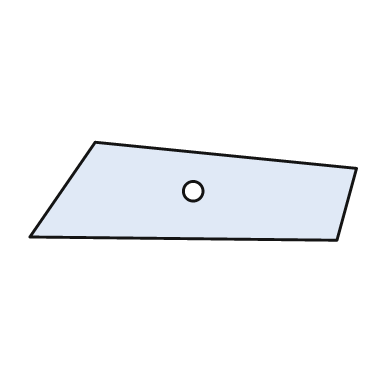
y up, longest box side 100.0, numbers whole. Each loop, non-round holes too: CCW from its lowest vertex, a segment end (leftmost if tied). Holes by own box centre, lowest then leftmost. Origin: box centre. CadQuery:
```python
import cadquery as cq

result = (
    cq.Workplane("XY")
    .moveTo(44.0, -15.0)
    .lineTo(50.0, 7.0)
    .lineTo(-30.0, 15.0)
    .lineTo(-50.0, -14.0)
    .close()
    .moveTo(0.0, 0.0)
    .circle(3.0)
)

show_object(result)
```